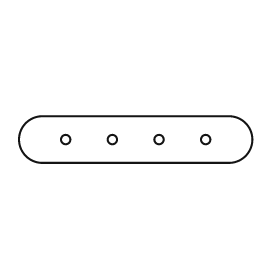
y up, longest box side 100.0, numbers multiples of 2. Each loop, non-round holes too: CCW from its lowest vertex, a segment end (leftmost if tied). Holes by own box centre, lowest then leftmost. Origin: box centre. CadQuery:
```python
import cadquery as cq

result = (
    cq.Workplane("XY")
    .moveTo(-40.0, -10.0)
    .lineTo(40.0, -10.0)
    .threePointArc((50.0, 0.0), (40.0, 10.0))
    .lineTo(-40.0, 10.0)
    .threePointArc((-50.0, 0.0), (-40.0, -10.0))
    .close()
    .moveTo(-30.0, 0.0)
    .circle(2.0)
    .moveTo(-10.0, 0.0)
    .circle(2.0)
    .moveTo(10.0, 0.0)
    .circle(2.0)
    .moveTo(30.0, 0.0)
    .circle(2.0)
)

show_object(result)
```